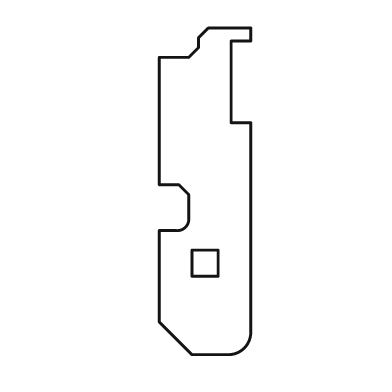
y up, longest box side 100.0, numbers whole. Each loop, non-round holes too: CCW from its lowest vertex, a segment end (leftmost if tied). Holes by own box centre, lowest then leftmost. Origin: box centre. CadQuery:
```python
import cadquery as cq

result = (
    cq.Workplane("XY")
    .moveTo(-4.0, -50.0)
    .lineTo(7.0, -50.0)
    .threePointArc((12.0, -48.0), (14.0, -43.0))
    .lineTo(14.0, 21.0)
    .lineTo(8.0, 21.0)
    .lineTo(8.0, 46.0)
    .lineTo(14.0, 46.0)
    .lineTo(14.0, 50.0)
    .lineTo(1.0, 50.0)
    .lineTo(-2.0, 47.0)
    .lineTo(-2.0, 44.0)
    .lineTo(-5.0, 41.0)
    .lineTo(-14.0, 41.0)
    .lineTo(-14.0, 2.0)
    .lineTo(-8.0, 2.0)
    .lineTo(-5.0, -1.0)
    .lineTo(-5.0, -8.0)
    .threePointArc((-6.0, -11.0), (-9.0, -12.0))
    .lineTo(-14.0, -12.0)
    .lineTo(-14.0, -40.0)
    .close()
    .moveTo(-4.0, -26.0)
    .lineTo(4.0, -26.0)
    .lineTo(4.0, -18.0)
    .lineTo(-4.0, -18.0)
    .close()
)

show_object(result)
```